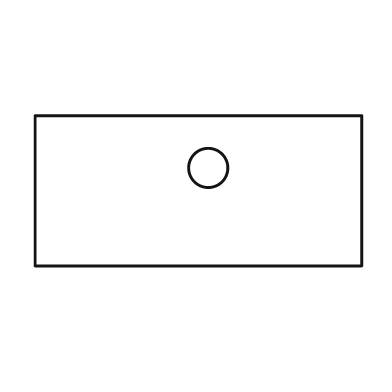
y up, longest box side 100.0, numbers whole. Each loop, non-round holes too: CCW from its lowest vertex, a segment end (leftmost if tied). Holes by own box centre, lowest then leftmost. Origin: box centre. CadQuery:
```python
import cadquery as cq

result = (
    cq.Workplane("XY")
    .moveTo(-50.0, -23.0)
    .lineTo(50.0, -23.0)
    .lineTo(50.0, 23.0)
    .lineTo(-50.0, 23.0)
    .close()
    .moveTo(3.0, 7.0)
    .circle(6.0)
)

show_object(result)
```